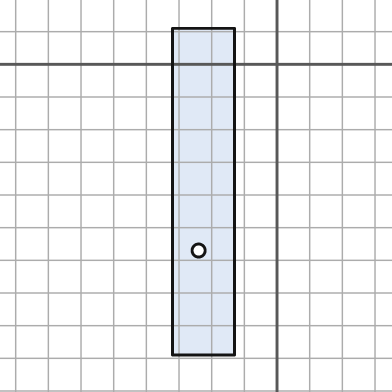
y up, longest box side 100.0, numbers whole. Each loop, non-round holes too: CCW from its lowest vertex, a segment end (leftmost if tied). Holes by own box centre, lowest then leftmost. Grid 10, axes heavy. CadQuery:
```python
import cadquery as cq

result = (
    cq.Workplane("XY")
    .moveTo(-32.0, -89.0)
    .lineTo(-13.0, -89.0)
    .lineTo(-13.0, 11.0)
    .lineTo(-32.0, 11.0)
    .close()
    .moveTo(-24.0, -57.0)
    .circle(2.0)
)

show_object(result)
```